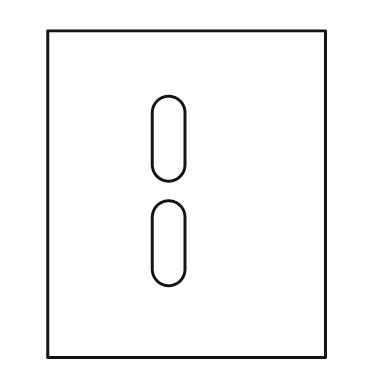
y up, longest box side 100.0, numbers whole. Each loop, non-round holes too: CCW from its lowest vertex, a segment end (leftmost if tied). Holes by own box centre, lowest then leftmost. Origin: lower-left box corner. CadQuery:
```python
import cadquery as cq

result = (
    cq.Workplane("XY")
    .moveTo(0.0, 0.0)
    .lineTo(85.0, 0.0)
    .lineTo(85.0, 100.0)
    .lineTo(0.0, 100.0)
    .close()
    .moveTo(32.0, 27.0)
    .threePointArc((37.0, 22.0), (42.0, 27.0))
    .lineTo(42.0, 43.0)
    .threePointArc((37.0, 48.0), (32.0, 43.0))
    .close()
    .moveTo(32.0, 59.0)
    .threePointArc((37.0, 54.0), (42.0, 59.0))
    .lineTo(42.0, 75.0)
    .threePointArc((37.0, 80.0), (32.0, 75.0))
    .close()
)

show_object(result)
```